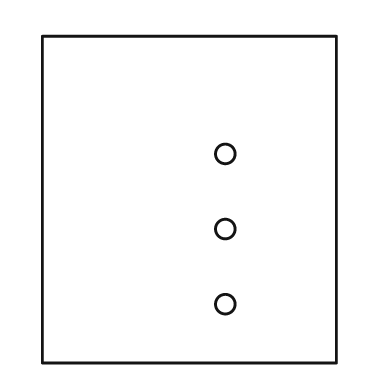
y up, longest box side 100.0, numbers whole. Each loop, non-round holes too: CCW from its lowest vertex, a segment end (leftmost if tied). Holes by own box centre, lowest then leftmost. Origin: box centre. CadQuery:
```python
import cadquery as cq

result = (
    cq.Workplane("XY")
    .moveTo(-45.0, -50.0)
    .lineTo(45.0, -50.0)
    .lineTo(45.0, 50.0)
    .lineTo(-45.0, 50.0)
    .close()
    .moveTo(11.0, -32.0)
    .circle(3.0)
    .moveTo(11.0, -9.0)
    .circle(3.0)
    .moveTo(11.0, 14.0)
    .circle(3.0)
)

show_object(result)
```